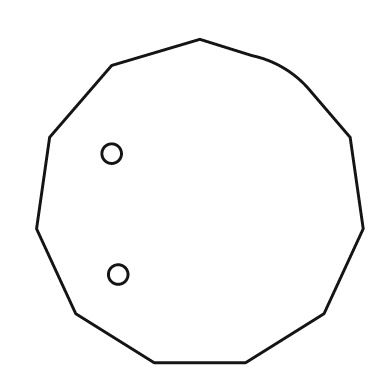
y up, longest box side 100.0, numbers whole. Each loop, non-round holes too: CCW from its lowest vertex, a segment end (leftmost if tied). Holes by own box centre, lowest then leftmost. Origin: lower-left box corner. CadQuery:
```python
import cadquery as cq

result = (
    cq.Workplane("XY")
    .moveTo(36.0, 0.0)
    .lineTo(64.0, 0.0)
    .lineTo(88.0, 15.0)
    .lineTo(100.0, 41.0)
    .lineTo(96.0, 69.0)
    .lineTo(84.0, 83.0)
    .threePointArc((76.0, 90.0), (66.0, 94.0))
    .lineTo(50.0, 99.0)
    .lineTo(23.0, 91.0)
    .lineTo(4.0, 69.0)
    .lineTo(0.0, 41.0)
    .lineTo(12.0, 15.0)
    .close()
    .moveTo(25.0, 27.0)
    .circle(3.0)
    .moveTo(23.0, 64.0)
    .circle(3.0)
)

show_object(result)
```